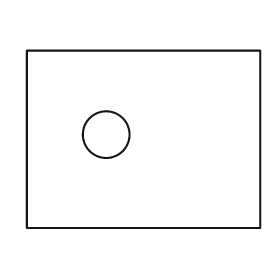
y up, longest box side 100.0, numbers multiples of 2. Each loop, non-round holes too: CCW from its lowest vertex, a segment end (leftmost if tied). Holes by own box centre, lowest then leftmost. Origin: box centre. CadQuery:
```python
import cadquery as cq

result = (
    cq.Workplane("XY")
    .moveTo(-50.0, -38.0)
    .lineTo(50.0, -38.0)
    .lineTo(50.0, 38.0)
    .lineTo(-50.0, 38.0)
    .close()
    .moveTo(-16.0, 2.0)
    .circle(10.0)
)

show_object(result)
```